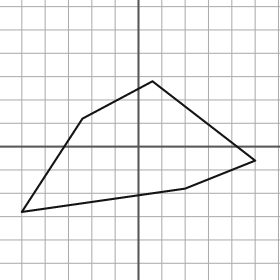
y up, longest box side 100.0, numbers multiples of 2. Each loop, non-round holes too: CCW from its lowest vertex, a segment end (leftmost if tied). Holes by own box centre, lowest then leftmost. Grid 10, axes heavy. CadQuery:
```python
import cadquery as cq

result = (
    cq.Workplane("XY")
    .moveTo(-50.0, -28.0)
    .lineTo(20.0, -18.0)
    .lineTo(50.0, -6.0)
    .lineTo(6.0, 28.0)
    .lineTo(-24.0, 12.0)
    .close()
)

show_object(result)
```